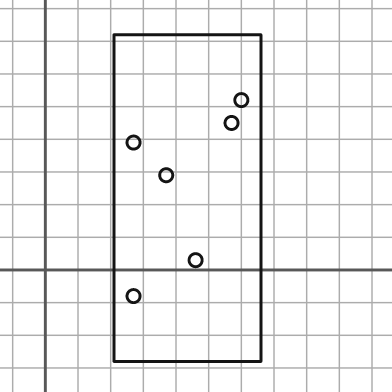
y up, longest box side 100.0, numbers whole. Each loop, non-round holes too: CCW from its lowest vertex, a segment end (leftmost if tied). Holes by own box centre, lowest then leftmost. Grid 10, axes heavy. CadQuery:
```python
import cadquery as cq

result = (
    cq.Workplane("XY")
    .moveTo(21.0, -28.0)
    .lineTo(66.0, -28.0)
    .lineTo(66.0, 72.0)
    .lineTo(21.0, 72.0)
    .close()
    .moveTo(27.0, -8.0)
    .circle(2.0)
    .moveTo(46.0, 3.0)
    .circle(2.0)
    .moveTo(37.0, 29.0)
    .circle(2.0)
    .moveTo(27.0, 39.0)
    .circle(2.0)
    .moveTo(57.0, 45.0)
    .circle(2.0)
    .moveTo(60.0, 52.0)
    .circle(2.0)
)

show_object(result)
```